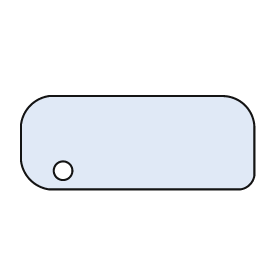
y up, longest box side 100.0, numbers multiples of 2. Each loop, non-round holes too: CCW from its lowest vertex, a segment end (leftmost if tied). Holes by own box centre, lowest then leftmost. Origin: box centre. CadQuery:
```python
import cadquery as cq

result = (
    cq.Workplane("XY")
    .moveTo(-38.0, -20.0)
    .lineTo(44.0, -20.0)
    .threePointArc((48.0, -18.0), (50.0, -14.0))
    .lineTo(50.0, 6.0)
    .threePointArc((46.0, 16.0), (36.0, 20.0))
    .lineTo(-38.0, 20.0)
    .threePointArc((-46.0, 16.0), (-50.0, 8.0))
    .lineTo(-50.0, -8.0)
    .threePointArc((-46.0, -16.0), (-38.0, -20.0))
    .close()
    .moveTo(-32.0, -12.0)
    .circle(4.0)
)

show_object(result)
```